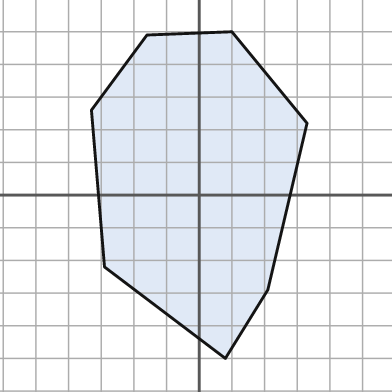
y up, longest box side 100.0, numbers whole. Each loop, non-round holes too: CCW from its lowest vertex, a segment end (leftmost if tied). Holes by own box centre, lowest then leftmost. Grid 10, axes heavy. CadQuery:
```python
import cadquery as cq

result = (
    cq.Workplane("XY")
    .moveTo(8.0, -50.0)
    .lineTo(21.0, -29.0)
    .lineTo(33.0, 22.0)
    .lineTo(10.0, 50.0)
    .lineTo(-16.0, 49.0)
    .lineTo(-33.0, 26.0)
    .lineTo(-29.0, -22.0)
    .close()
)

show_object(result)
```